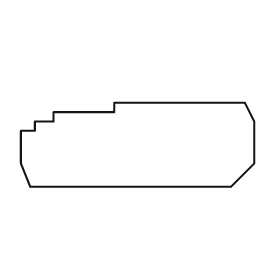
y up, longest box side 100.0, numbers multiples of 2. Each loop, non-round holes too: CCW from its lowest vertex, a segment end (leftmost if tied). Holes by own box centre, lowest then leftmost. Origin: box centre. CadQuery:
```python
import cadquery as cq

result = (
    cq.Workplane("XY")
    .moveTo(-46.0, -18.0)
    .lineTo(40.0, -18.0)
    .lineTo(50.0, -8.0)
    .lineTo(50.0, 10.0)
    .lineTo(46.0, 18.0)
    .lineTo(-10.0, 18.0)
    .lineTo(-10.0, 14.0)
    .lineTo(-36.0, 14.0)
    .lineTo(-36.0, 10.0)
    .lineTo(-44.0, 10.0)
    .lineTo(-44.0, 6.0)
    .lineTo(-50.0, 6.0)
    .lineTo(-50.0, -8.0)
    .close()
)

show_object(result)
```